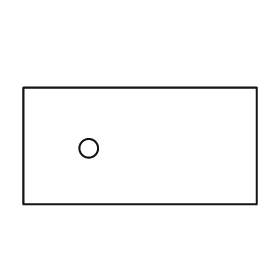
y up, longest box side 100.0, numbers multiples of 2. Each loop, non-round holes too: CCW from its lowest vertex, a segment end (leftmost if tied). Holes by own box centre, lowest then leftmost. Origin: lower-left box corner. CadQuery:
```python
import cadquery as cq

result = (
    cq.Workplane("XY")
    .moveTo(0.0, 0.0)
    .lineTo(100.0, 0.0)
    .lineTo(100.0, 50.0)
    .lineTo(0.0, 50.0)
    .close()
    .moveTo(28.0, 24.0)
    .circle(4.0)
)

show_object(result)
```